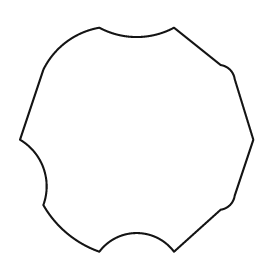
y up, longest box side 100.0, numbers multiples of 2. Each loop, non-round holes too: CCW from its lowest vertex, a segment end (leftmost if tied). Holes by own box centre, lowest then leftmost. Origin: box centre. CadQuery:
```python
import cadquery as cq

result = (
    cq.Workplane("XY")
    .moveTo(-16.0, -48.0)
    .threePointArc((0.0, -40.0), (16.0, -48.0))
    .lineTo(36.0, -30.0)
    .threePointArc((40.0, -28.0), (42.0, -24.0))
    .lineTo(50.0, 0.0)
    .lineTo(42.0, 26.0)
    .threePointArc((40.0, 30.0), (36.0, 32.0))
    .lineTo(16.0, 48.0)
    .threePointArc((0.0, 44.0), (-16.0, 48.0))
    .threePointArc((-30.0, 42.0), (-40.0, 30.0))
    .lineTo(-50.0, 0.0)
    .threePointArc((-40.0, -12.0), (-40.0, -28.0))
    .threePointArc((-30.0, -40.0), (-16.0, -48.0))
    .close()
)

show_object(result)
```